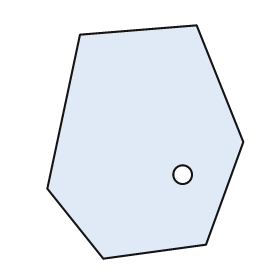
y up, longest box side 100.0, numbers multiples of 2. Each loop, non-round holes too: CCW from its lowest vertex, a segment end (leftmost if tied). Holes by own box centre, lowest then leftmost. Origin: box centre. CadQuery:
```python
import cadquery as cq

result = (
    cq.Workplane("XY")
    .moveTo(-18.0, -50.0)
    .lineTo(26.0, -44.0)
    .lineTo(42.0, 0.0)
    .lineTo(22.0, 50.0)
    .lineTo(-28.0, 46.0)
    .lineTo(-42.0, -20.0)
    .close()
    .moveTo(16.0, -14.0)
    .circle(4.0)
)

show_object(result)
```